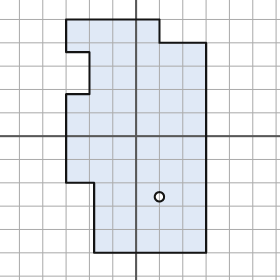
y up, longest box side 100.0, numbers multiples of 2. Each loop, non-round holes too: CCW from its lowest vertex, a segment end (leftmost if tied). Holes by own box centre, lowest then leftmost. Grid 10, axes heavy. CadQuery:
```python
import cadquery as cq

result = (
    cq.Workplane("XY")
    .moveTo(-18.0, -50.0)
    .lineTo(30.0, -50.0)
    .lineTo(30.0, 40.0)
    .lineTo(10.0, 40.0)
    .lineTo(10.0, 50.0)
    .lineTo(-30.0, 50.0)
    .lineTo(-30.0, 36.0)
    .lineTo(-20.0, 36.0)
    .lineTo(-20.0, 18.0)
    .lineTo(-30.0, 18.0)
    .lineTo(-30.0, -20.0)
    .lineTo(-18.0, -20.0)
    .close()
    .moveTo(10.0, -26.0)
    .circle(2.0)
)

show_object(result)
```